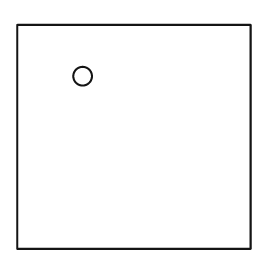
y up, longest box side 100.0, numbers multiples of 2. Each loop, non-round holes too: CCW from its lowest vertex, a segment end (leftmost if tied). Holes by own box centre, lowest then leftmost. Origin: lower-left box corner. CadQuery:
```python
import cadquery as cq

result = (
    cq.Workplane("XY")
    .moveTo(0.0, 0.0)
    .lineTo(100.0, 0.0)
    .lineTo(100.0, 96.0)
    .lineTo(0.0, 96.0)
    .close()
    .moveTo(28.0, 74.0)
    .circle(4.0)
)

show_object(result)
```